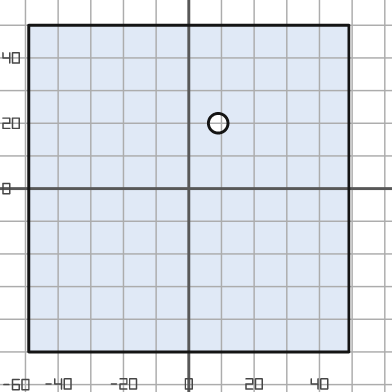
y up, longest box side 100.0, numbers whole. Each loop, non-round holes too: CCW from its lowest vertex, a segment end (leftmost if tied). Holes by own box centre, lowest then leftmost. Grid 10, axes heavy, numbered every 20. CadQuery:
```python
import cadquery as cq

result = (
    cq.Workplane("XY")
    .moveTo(-49.0, -50.0)
    .lineTo(49.0, -50.0)
    .lineTo(49.0, 50.0)
    .lineTo(-49.0, 50.0)
    .close()
    .moveTo(9.0, 20.0)
    .circle(3.0)
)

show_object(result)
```